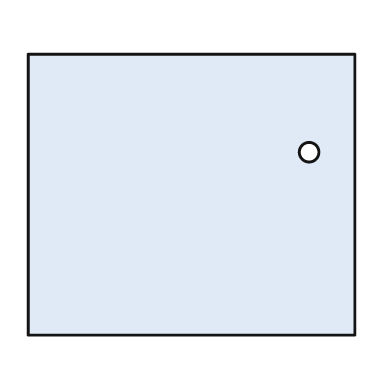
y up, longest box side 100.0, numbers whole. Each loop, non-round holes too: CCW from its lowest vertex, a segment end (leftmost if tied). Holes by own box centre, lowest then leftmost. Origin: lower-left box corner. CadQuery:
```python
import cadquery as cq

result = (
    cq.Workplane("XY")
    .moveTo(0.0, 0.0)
    .lineTo(100.0, 0.0)
    .lineTo(100.0, 86.0)
    .lineTo(0.0, 86.0)
    .close()
    .moveTo(86.0, 56.0)
    .circle(3.0)
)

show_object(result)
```